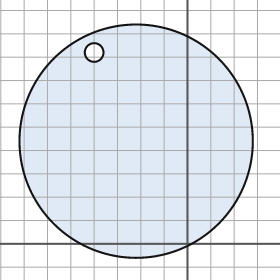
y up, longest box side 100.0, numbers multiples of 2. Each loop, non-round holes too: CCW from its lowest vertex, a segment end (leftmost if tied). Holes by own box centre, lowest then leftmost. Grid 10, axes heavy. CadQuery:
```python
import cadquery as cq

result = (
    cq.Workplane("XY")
    .moveTo(-22.0, 44.0)
    .circle(50.0)
    .moveTo(-40.0, 82.0)
    .circle(4.0)
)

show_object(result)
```